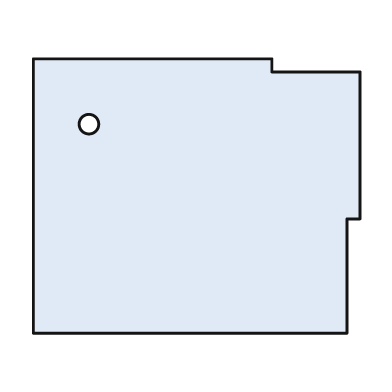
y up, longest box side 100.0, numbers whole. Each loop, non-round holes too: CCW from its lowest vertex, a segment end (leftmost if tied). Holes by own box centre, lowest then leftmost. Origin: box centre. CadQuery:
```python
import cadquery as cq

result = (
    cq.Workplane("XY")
    .moveTo(-50.0, -42.0)
    .lineTo(46.0, -42.0)
    .lineTo(46.0, -7.0)
    .lineTo(50.0, -7.0)
    .lineTo(50.0, 38.0)
    .lineTo(23.0, 38.0)
    .lineTo(23.0, 42.0)
    .lineTo(-50.0, 42.0)
    .close()
    .moveTo(-33.0, 22.0)
    .circle(3.0)
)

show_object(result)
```